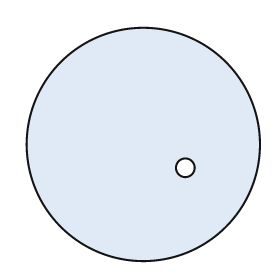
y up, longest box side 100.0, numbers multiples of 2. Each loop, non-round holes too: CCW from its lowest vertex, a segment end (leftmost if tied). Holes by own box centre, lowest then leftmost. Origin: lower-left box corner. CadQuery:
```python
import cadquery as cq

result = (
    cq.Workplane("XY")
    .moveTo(50.0, 50.0)
    .circle(50.0)
    .moveTo(68.0, 40.0)
    .circle(4.0)
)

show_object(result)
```